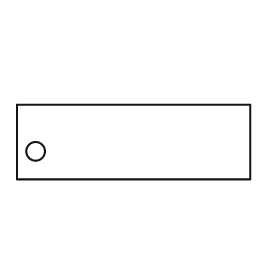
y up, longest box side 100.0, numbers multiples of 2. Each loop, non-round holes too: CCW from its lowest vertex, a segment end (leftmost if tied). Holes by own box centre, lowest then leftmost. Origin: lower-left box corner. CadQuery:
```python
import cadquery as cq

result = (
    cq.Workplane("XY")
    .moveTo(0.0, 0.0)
    .lineTo(100.0, 0.0)
    .lineTo(100.0, 32.0)
    .lineTo(0.0, 32.0)
    .close()
    .moveTo(8.0, 12.0)
    .circle(4.0)
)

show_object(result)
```